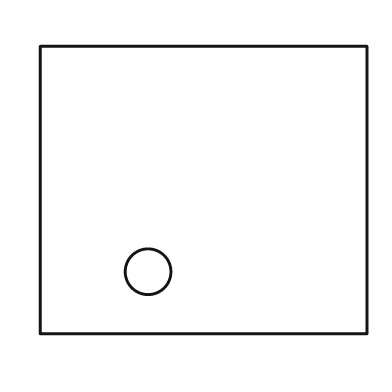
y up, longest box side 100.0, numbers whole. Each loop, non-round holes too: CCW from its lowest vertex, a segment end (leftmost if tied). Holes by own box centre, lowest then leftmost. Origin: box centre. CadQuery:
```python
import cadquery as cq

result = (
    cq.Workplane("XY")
    .moveTo(-50.0, -44.0)
    .lineTo(50.0, -44.0)
    .lineTo(50.0, 44.0)
    .lineTo(-50.0, 44.0)
    .close()
    .moveTo(-17.0, -25.0)
    .circle(7.0)
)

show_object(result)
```